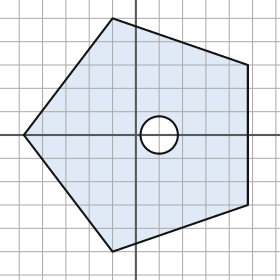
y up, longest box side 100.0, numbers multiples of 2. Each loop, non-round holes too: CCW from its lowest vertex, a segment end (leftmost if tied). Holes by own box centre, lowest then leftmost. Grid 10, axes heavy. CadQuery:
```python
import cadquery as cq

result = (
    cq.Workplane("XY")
    .moveTo(-10.0, -50.0)
    .lineTo(48.0, -30.0)
    .lineTo(48.0, 30.0)
    .lineTo(-10.0, 50.0)
    .lineTo(-48.0, 0.0)
    .close()
    .moveTo(10.0, 0.0)
    .circle(8.0)
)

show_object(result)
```